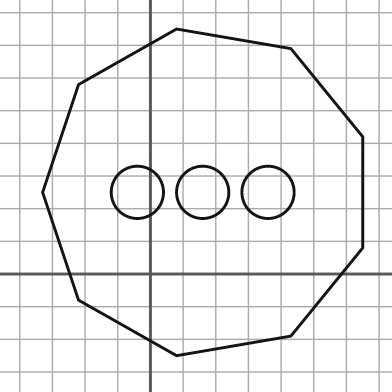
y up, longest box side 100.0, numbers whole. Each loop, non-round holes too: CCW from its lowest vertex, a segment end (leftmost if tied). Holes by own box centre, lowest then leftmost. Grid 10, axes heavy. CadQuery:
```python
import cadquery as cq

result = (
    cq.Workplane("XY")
    .moveTo(8.0, -25.0)
    .lineTo(43.0, -19.0)
    .lineTo(65.0, 8.0)
    .lineTo(65.0, 42.0)
    .lineTo(43.0, 69.0)
    .lineTo(8.0, 75.0)
    .lineTo(-22.0, 58.0)
    .lineTo(-33.0, 25.0)
    .lineTo(-22.0, -8.0)
    .close()
    .moveTo(-4.0, 25.0)
    .circle(8.0)
    .moveTo(16.0, 25.0)
    .circle(8.0)
    .moveTo(36.0, 25.0)
    .circle(8.0)
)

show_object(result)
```